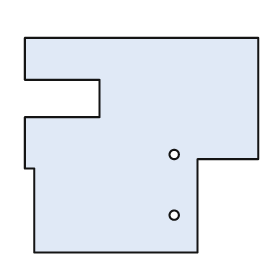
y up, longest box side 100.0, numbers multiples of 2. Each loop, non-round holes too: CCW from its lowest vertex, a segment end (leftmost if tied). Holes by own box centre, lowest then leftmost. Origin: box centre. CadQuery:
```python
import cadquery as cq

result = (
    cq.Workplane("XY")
    .moveTo(-46.0, -46.0)
    .lineTo(24.0, -46.0)
    .lineTo(24.0, -6.0)
    .lineTo(50.0, -6.0)
    .lineTo(50.0, 46.0)
    .lineTo(-50.0, 46.0)
    .lineTo(-50.0, 28.0)
    .lineTo(-18.0, 28.0)
    .lineTo(-18.0, 12.0)
    .lineTo(-50.0, 12.0)
    .lineTo(-50.0, -10.0)
    .lineTo(-46.0, -10.0)
    .close()
    .moveTo(14.0, -30.0)
    .circle(2.0)
    .moveTo(14.0, -4.0)
    .circle(2.0)
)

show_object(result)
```